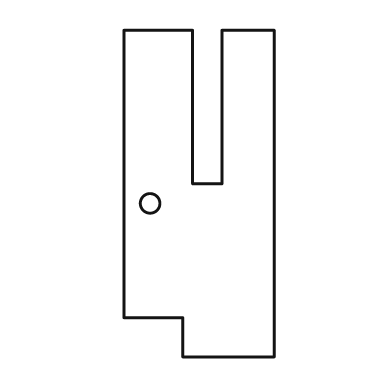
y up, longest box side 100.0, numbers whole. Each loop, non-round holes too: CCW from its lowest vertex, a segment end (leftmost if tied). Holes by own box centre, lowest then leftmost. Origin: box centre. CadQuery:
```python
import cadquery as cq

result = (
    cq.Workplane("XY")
    .moveTo(-5.0, -50.0)
    .lineTo(23.0, -50.0)
    .lineTo(23.0, 50.0)
    .lineTo(7.0, 50.0)
    .lineTo(7.0, 3.0)
    .lineTo(-2.0, 3.0)
    .lineTo(-2.0, 50.0)
    .lineTo(-23.0, 50.0)
    .lineTo(-23.0, -38.0)
    .lineTo(-5.0, -38.0)
    .close()
    .moveTo(-15.0, -3.0)
    .circle(3.0)
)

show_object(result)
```